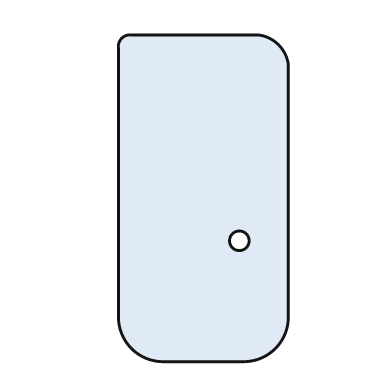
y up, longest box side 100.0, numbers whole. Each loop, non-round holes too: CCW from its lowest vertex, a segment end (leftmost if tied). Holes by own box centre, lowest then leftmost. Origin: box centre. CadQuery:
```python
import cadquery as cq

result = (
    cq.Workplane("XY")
    .moveTo(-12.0, -50.0)
    .lineTo(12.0, -50.0)
    .threePointArc((22.0, -46.0), (26.0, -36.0))
    .lineTo(26.0, 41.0)
    .threePointArc((23.0, 47.0), (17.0, 50.0))
    .lineTo(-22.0, 50.0)
    .threePointArc((-25.0, 49.0), (-26.0, 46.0))
    .lineTo(-26.0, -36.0)
    .threePointArc((-22.0, -46.0), (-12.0, -50.0))
    .close()
    .moveTo(11.0, -13.0)
    .circle(3.0)
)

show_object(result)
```